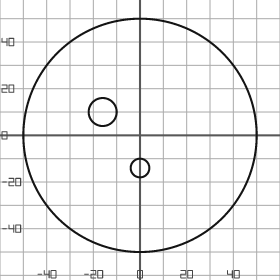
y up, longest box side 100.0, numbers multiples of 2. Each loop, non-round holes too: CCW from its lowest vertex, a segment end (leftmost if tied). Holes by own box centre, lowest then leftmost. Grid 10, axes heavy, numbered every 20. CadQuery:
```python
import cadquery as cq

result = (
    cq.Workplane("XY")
    .moveTo(0.0, 0.0)
    .circle(50.0)
    .moveTo(0.0, -14.0)
    .circle(4.0)
    .moveTo(-16.0, 10.0)
    .circle(6.0)
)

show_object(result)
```